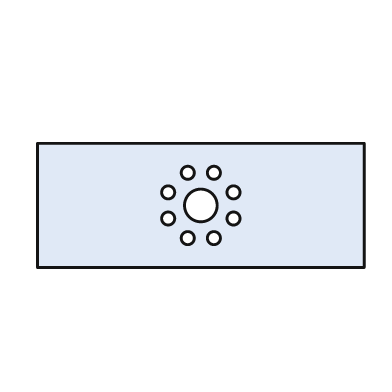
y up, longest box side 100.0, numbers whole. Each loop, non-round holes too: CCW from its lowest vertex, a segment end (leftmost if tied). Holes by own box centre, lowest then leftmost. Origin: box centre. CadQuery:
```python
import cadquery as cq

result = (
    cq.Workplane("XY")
    .moveTo(-50.0, -19.0)
    .lineTo(50.0, -19.0)
    .lineTo(50.0, 19.0)
    .lineTo(-50.0, 19.0)
    .close()
    .moveTo(-4.0, -10.0)
    .circle(2.0)
    .moveTo(4.0, -10.0)
    .circle(2.0)
    .moveTo(-10.0, -4.0)
    .circle(2.0)
    .moveTo(10.0, -4.0)
    .circle(2.0)
    .moveTo(0.0, 0.0)
    .circle(5.0)
    .moveTo(-10.0, 4.0)
    .circle(2.0)
    .moveTo(10.0, 4.0)
    .circle(2.0)
    .moveTo(-4.0, 10.0)
    .circle(2.0)
    .moveTo(4.0, 10.0)
    .circle(2.0)
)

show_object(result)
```